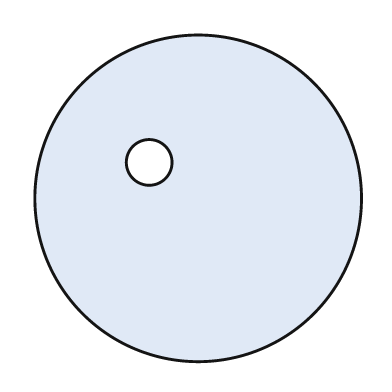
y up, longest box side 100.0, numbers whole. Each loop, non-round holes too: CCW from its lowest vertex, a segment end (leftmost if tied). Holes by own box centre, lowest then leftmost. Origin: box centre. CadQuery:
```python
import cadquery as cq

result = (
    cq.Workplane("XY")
    .moveTo(0.0, 0.0)
    .circle(50.0)
    .moveTo(-15.0, 11.0)
    .circle(7.0)
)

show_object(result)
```